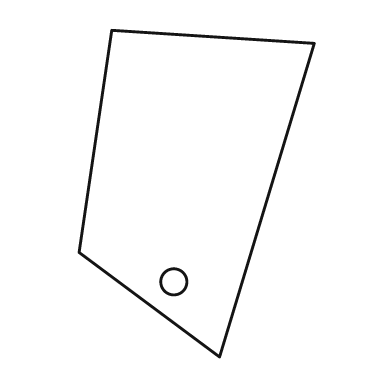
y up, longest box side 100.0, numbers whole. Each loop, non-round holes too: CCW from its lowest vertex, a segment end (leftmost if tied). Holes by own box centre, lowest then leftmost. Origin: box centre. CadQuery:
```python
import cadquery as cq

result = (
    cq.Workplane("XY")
    .moveTo(7.0, -50.0)
    .lineTo(36.0, 46.0)
    .lineTo(-26.0, 50.0)
    .lineTo(-36.0, -18.0)
    .close()
    .moveTo(-7.0, -27.0)
    .circle(4.0)
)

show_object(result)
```